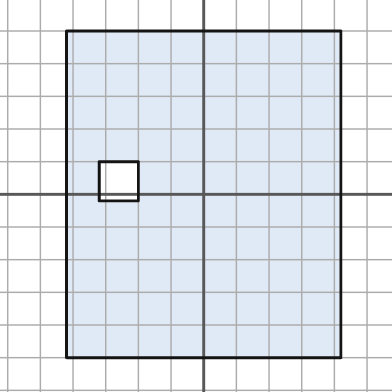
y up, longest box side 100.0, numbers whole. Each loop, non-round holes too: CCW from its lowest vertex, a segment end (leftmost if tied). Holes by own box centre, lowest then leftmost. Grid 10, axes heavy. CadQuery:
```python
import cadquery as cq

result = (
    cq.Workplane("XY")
    .moveTo(-42.0, -50.0)
    .lineTo(42.0, -50.0)
    .lineTo(42.0, 50.0)
    .lineTo(-42.0, 50.0)
    .close()
    .moveTo(-32.0, -2.0)
    .lineTo(-20.0, -2.0)
    .lineTo(-20.0, 10.0)
    .lineTo(-32.0, 10.0)
    .close()
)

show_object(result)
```